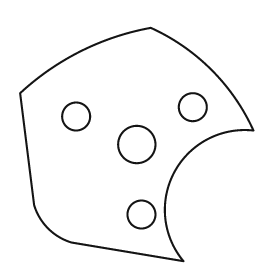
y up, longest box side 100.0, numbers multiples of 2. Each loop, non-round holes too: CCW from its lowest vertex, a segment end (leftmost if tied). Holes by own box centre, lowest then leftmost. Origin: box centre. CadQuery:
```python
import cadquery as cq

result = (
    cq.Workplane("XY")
    .moveTo(20.0, -50.0)
    .threePointArc((16.0, -12.0), (50.0, 6.0))
    .threePointArc((32.0, 32.0), (6.0, 50.0))
    .threePointArc((-24.0, 40.0), (-50.0, 22.0))
    .lineTo(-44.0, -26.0)
    .threePointArc((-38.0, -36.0), (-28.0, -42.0))
    .close()
    .moveTo(2.0, -30.0)
    .circle(6.0)
    .moveTo(0.0, 0.0)
    .circle(8.0)
    .moveTo(-26.0, 12.0)
    .circle(6.0)
    .moveTo(24.0, 16.0)
    .circle(6.0)
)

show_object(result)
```